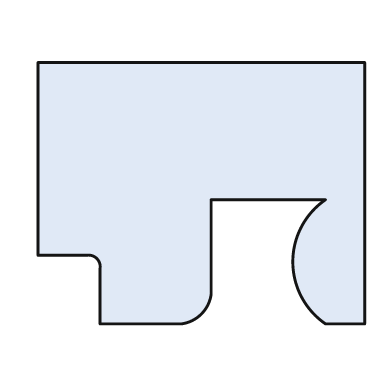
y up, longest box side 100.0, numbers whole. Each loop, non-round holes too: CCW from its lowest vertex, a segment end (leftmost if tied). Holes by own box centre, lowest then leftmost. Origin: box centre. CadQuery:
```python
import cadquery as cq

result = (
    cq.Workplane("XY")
    .moveTo(-31.0, -40.0)
    .lineTo(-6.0, -40.0)
    .threePointArc((0.0, -37.0), (3.0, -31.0))
    .lineTo(3.0, -2.0)
    .lineTo(38.0, -2.0)
    .threePointArc((28.0, -21.0), (38.0, -40.0))
    .lineTo(50.0, -40.0)
    .lineTo(50.0, 40.0)
    .lineTo(-50.0, 40.0)
    .lineTo(-50.0, -19.0)
    .lineTo(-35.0, -19.0)
    .threePointArc((-32.0, -20.0), (-31.0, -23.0))
    .close()
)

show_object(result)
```